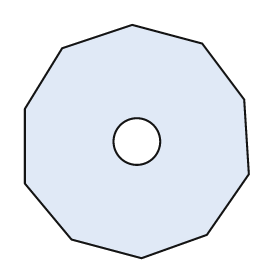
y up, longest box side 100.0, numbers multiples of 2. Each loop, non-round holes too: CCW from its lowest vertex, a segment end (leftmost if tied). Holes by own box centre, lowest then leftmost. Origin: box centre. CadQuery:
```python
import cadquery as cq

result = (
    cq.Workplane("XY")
    .moveTo(2.0, -50.0)
    .lineTo(30.0, -40.0)
    .lineTo(48.0, -14.0)
    .lineTo(46.0, 18.0)
    .lineTo(28.0, 42.0)
    .lineTo(-2.0, 50.0)
    .lineTo(-32.0, 40.0)
    .lineTo(-48.0, 14.0)
    .lineTo(-48.0, -18.0)
    .lineTo(-28.0, -42.0)
    .close()
    .moveTo(0.0, 0.0)
    .circle(10.0)
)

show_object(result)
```